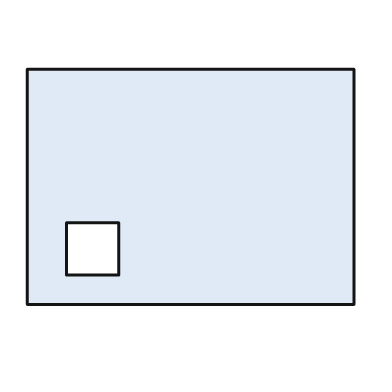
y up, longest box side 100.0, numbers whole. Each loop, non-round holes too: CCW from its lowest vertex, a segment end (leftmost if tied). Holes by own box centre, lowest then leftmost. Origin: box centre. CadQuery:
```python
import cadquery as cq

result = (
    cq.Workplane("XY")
    .moveTo(-50.0, -36.0)
    .lineTo(50.0, -36.0)
    .lineTo(50.0, 36.0)
    .lineTo(-50.0, 36.0)
    .close()
    .moveTo(-38.0, -27.0)
    .lineTo(-22.0, -27.0)
    .lineTo(-22.0, -11.0)
    .lineTo(-38.0, -11.0)
    .close()
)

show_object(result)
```